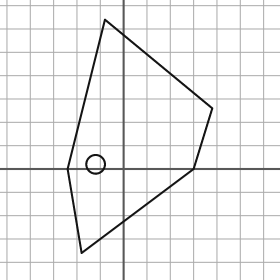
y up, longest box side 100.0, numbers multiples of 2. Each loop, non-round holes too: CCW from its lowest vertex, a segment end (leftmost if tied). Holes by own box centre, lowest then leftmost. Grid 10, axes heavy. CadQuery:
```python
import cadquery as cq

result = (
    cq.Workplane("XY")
    .moveTo(-18.0, -36.0)
    .lineTo(30.0, 0.0)
    .lineTo(38.0, 26.0)
    .lineTo(-8.0, 64.0)
    .lineTo(-24.0, 0.0)
    .close()
    .moveTo(-12.0, 2.0)
    .circle(4.0)
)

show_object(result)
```